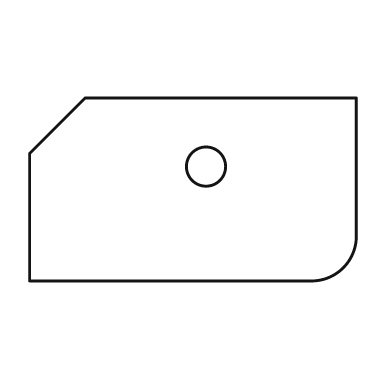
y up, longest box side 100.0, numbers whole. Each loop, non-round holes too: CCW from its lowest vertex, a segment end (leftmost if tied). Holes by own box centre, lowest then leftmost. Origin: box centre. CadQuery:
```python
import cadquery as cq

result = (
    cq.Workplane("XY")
    .moveTo(-50.0, -28.0)
    .lineTo(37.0, -28.0)
    .threePointArc((46.0, -24.0), (50.0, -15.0))
    .lineTo(50.0, 28.0)
    .lineTo(-33.0, 28.0)
    .lineTo(-50.0, 11.0)
    .close()
    .moveTo(4.0, 7.0)
    .circle(6.0)
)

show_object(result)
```